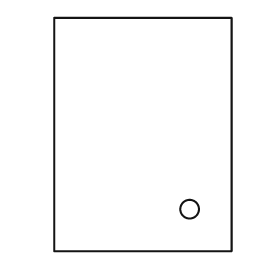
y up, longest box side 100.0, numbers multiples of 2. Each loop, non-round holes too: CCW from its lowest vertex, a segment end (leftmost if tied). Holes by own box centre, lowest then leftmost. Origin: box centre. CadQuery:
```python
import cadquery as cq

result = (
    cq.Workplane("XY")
    .moveTo(-38.0, -50.0)
    .lineTo(38.0, -50.0)
    .lineTo(38.0, 50.0)
    .lineTo(-38.0, 50.0)
    .close()
    .moveTo(20.0, -32.0)
    .circle(4.0)
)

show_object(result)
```